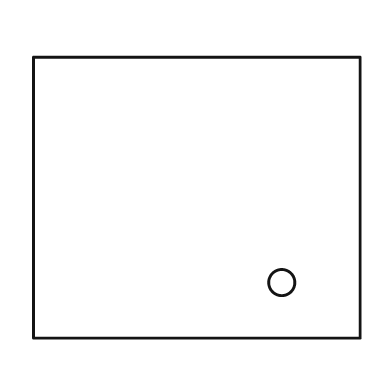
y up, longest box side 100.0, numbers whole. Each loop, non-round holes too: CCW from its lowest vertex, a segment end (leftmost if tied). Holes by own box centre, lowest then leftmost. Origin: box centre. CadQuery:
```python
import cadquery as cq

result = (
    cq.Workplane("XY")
    .moveTo(-50.0, -43.0)
    .lineTo(50.0, -43.0)
    .lineTo(50.0, 43.0)
    .lineTo(-50.0, 43.0)
    .close()
    .moveTo(26.0, -26.0)
    .circle(4.0)
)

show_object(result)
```